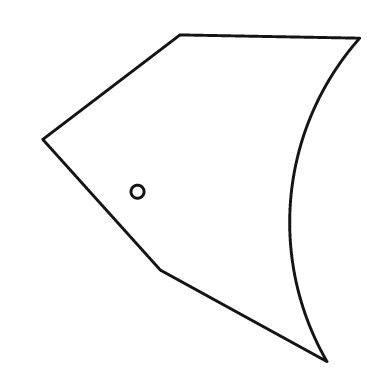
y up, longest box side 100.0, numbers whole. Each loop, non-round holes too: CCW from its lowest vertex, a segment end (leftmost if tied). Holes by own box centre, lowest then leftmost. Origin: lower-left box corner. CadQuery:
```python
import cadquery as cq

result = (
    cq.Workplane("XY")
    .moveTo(87.0, 0.0)
    .threePointArc((76.0, 51.0), (97.0, 99.0))
    .lineTo(42.0, 100.0)
    .lineTo(0.0, 68.0)
    .lineTo(36.0, 28.0)
    .close()
    .moveTo(29.0, 52.0)
    .circle(2.0)
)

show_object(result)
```